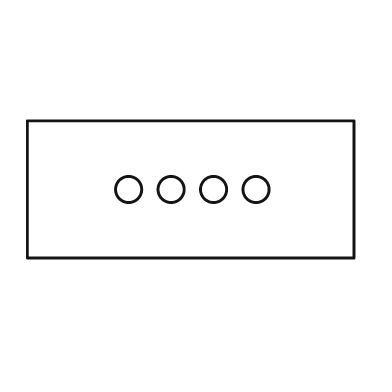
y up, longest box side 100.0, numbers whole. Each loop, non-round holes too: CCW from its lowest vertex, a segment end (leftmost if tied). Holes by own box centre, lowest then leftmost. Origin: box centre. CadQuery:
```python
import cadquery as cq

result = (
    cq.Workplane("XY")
    .moveTo(-50.0, -21.0)
    .lineTo(50.0, -21.0)
    .lineTo(50.0, 21.0)
    .lineTo(-50.0, 21.0)
    .close()
    .moveTo(-19.0, 0.0)
    .circle(4.0)
    .moveTo(-6.0, 0.0)
    .circle(4.0)
    .moveTo(7.0, 0.0)
    .circle(4.0)
    .moveTo(20.0, 0.0)
    .circle(4.0)
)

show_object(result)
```